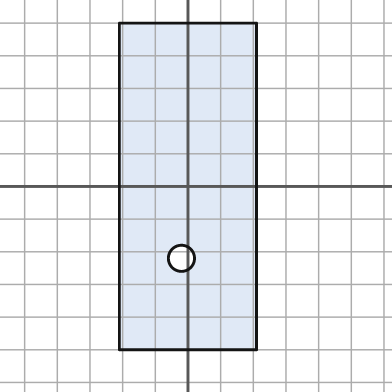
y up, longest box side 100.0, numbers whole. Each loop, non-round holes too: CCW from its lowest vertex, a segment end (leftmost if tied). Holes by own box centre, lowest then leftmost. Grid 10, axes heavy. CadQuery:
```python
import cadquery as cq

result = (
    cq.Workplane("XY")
    .moveTo(-21.0, -50.0)
    .lineTo(21.0, -50.0)
    .lineTo(21.0, 50.0)
    .lineTo(-21.0, 50.0)
    .close()
    .moveTo(-2.0, -22.0)
    .circle(4.0)
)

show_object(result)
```